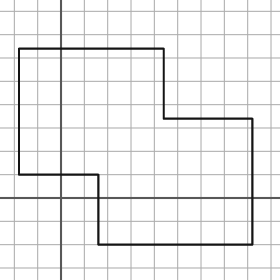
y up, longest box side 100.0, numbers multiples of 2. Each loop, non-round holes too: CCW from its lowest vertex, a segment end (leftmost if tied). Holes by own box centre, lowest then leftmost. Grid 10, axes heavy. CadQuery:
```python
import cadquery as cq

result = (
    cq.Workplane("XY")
    .moveTo(16.0, -20.0)
    .lineTo(82.0, -20.0)
    .lineTo(82.0, 34.0)
    .lineTo(44.0, 34.0)
    .lineTo(44.0, 64.0)
    .lineTo(-18.0, 64.0)
    .lineTo(-18.0, 10.0)
    .lineTo(16.0, 10.0)
    .close()
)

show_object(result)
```